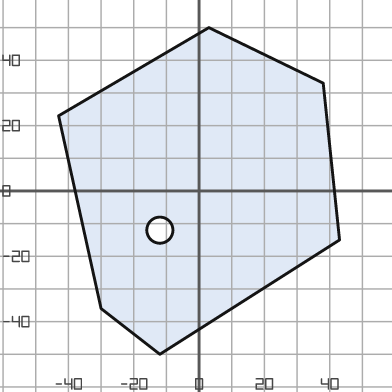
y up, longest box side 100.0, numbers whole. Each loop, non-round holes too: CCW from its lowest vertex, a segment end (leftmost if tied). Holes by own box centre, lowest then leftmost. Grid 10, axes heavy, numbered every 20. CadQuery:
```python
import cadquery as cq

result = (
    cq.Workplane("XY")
    .moveTo(-12.0, -50.0)
    .lineTo(43.0, -15.0)
    .lineTo(38.0, 33.0)
    .lineTo(3.0, 50.0)
    .lineTo(-43.0, 23.0)
    .lineTo(-30.0, -36.0)
    .close()
    .moveTo(-12.0, -12.0)
    .circle(4.0)
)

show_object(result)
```